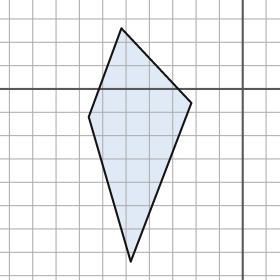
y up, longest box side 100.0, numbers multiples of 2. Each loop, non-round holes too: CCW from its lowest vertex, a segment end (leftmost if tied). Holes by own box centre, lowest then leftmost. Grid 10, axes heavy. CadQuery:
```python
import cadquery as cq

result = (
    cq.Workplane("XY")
    .moveTo(-48.0, -74.0)
    .lineTo(-22.0, -6.0)
    .lineTo(-52.0, 26.0)
    .lineTo(-66.0, -12.0)
    .close()
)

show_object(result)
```